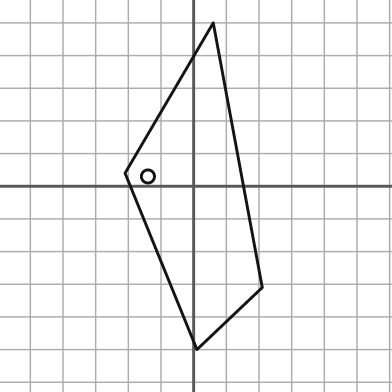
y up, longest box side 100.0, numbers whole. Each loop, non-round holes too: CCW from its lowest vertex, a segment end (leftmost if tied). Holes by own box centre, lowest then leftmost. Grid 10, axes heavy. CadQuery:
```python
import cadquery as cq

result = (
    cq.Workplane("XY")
    .moveTo(1.0, -50.0)
    .lineTo(21.0, -31.0)
    .lineTo(6.0, 50.0)
    .lineTo(-21.0, 4.0)
    .close()
    .moveTo(-14.0, 3.0)
    .circle(2.0)
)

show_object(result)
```